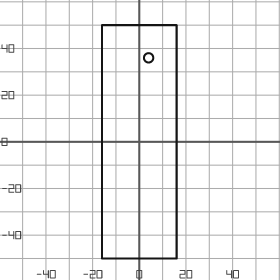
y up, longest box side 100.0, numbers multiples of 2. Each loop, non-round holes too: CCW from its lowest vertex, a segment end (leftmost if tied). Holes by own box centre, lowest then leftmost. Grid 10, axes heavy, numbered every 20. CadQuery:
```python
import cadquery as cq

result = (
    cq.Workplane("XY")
    .moveTo(-16.0, -50.0)
    .lineTo(16.0, -50.0)
    .lineTo(16.0, 50.0)
    .lineTo(-16.0, 50.0)
    .close()
    .moveTo(4.0, 36.0)
    .circle(2.0)
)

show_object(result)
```